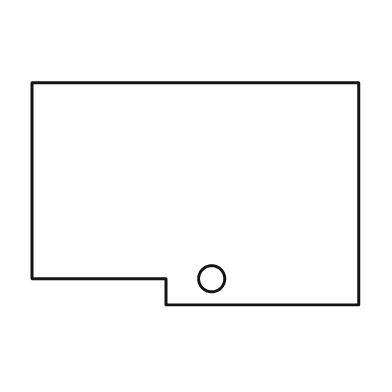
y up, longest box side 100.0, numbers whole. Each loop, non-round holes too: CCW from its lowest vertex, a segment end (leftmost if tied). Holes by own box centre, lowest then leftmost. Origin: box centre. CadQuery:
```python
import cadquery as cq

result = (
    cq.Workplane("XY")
    .moveTo(-9.0, -34.0)
    .lineTo(50.0, -34.0)
    .lineTo(50.0, 34.0)
    .lineTo(-50.0, 34.0)
    .lineTo(-50.0, -26.0)
    .lineTo(-9.0, -26.0)
    .close()
    .moveTo(5.0, -26.0)
    .circle(4.0)
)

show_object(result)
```